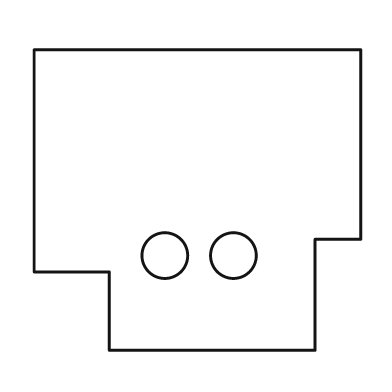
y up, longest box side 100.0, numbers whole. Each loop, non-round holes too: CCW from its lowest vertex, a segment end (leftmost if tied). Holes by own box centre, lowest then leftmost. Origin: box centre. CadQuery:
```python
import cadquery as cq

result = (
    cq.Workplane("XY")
    .moveTo(-27.0, -46.0)
    .lineTo(36.0, -46.0)
    .lineTo(36.0, -12.0)
    .lineTo(50.0, -12.0)
    .lineTo(50.0, 46.0)
    .lineTo(-50.0, 46.0)
    .lineTo(-50.0, -22.0)
    .lineTo(-27.0, -22.0)
    .close()
    .moveTo(-10.0, -17.0)
    .circle(7.0)
    .moveTo(11.0, -17.0)
    .circle(7.0)
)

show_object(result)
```